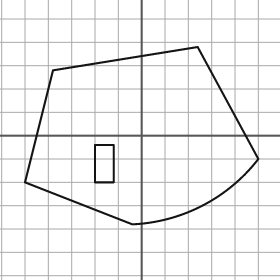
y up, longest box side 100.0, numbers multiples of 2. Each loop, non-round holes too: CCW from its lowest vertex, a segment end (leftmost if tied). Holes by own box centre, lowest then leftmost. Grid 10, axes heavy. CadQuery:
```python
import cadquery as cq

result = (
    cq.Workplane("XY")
    .moveTo(-4.0, -38.0)
    .threePointArc((26.0, -30.0), (50.0, -10.0))
    .lineTo(24.0, 38.0)
    .lineTo(-38.0, 28.0)
    .lineTo(-50.0, -20.0)
    .close()
    .moveTo(-20.0, -20.0)
    .lineTo(-12.0, -20.0)
    .lineTo(-12.0, -4.0)
    .lineTo(-20.0, -4.0)
    .close()
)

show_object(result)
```